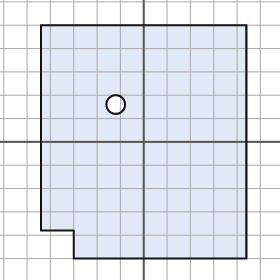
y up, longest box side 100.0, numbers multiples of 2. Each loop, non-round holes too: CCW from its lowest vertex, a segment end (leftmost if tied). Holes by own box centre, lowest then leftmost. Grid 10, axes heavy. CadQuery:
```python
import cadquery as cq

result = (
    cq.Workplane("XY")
    .moveTo(-30.0, -50.0)
    .lineTo(44.0, -50.0)
    .lineTo(44.0, 50.0)
    .lineTo(-44.0, 50.0)
    .lineTo(-44.0, -38.0)
    .lineTo(-30.0, -38.0)
    .close()
    .moveTo(-12.0, 16.0)
    .circle(4.0)
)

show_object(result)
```